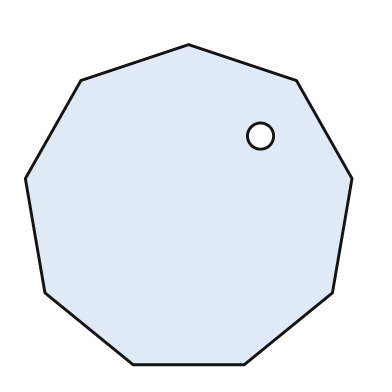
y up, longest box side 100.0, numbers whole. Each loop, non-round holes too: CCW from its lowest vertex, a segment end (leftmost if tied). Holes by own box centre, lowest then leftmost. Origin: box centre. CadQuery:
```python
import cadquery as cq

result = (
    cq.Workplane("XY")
    .moveTo(-17.0, -49.0)
    .lineTo(17.0, -49.0)
    .lineTo(44.0, -27.0)
    .lineTo(50.0, 8.0)
    .lineTo(33.0, 38.0)
    .lineTo(0.0, 49.0)
    .lineTo(-33.0, 38.0)
    .lineTo(-50.0, 8.0)
    .lineTo(-44.0, -27.0)
    .close()
    .moveTo(22.0, 21.0)
    .circle(4.0)
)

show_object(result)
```